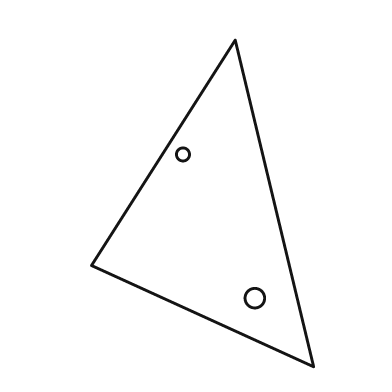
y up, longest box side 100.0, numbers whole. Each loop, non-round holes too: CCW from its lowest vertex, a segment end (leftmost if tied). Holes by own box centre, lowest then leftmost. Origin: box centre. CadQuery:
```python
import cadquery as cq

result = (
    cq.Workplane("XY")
    .moveTo(34.0, -50.0)
    .lineTo(10.0, 50.0)
    .lineTo(-34.0, -19.0)
    .close()
    .moveTo(16.0, -29.0)
    .circle(3.0)
    .moveTo(-6.0, 15.0)
    .circle(2.0)
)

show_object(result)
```